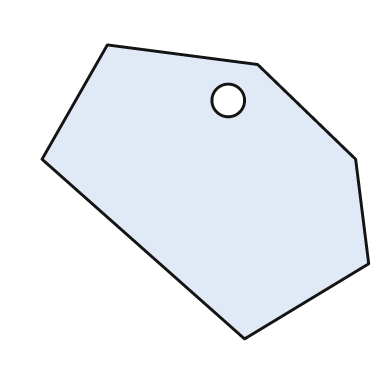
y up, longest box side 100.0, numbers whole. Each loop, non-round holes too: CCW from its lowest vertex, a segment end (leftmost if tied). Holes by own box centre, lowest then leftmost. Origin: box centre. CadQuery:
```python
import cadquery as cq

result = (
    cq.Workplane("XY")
    .moveTo(12.0, -45.0)
    .lineTo(50.0, -22.0)
    .lineTo(46.0, 10.0)
    .lineTo(16.0, 39.0)
    .lineTo(-30.0, 45.0)
    .lineTo(-50.0, 10.0)
    .close()
    .moveTo(7.0, 28.0)
    .circle(5.0)
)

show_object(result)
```